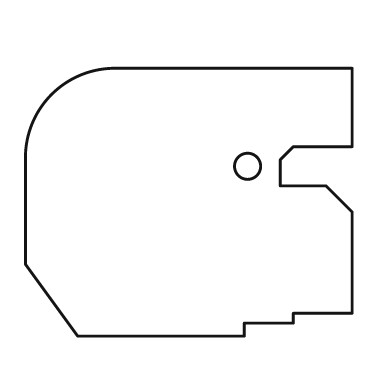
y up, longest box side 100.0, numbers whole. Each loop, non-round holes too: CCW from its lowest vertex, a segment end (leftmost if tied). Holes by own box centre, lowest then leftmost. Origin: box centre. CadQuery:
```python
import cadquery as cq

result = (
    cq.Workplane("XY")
    .moveTo(-34.0, -41.0)
    .lineTo(17.0, -41.0)
    .lineTo(17.0, -37.0)
    .lineTo(32.0, -37.0)
    .lineTo(32.0, -34.0)
    .lineTo(50.0, -34.0)
    .lineTo(50.0, -3.0)
    .lineTo(42.0, 5.0)
    .lineTo(28.0, 5.0)
    .lineTo(28.0, 13.0)
    .lineTo(32.0, 17.0)
    .lineTo(50.0, 17.0)
    .lineTo(50.0, 41.0)
    .lineTo(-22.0, 41.0)
    .threePointArc((-42.0, 33.0), (-50.0, 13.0))
    .lineTo(-50.0, -19.0)
    .close()
    .moveTo(18.0, 11.0)
    .circle(4.0)
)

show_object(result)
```